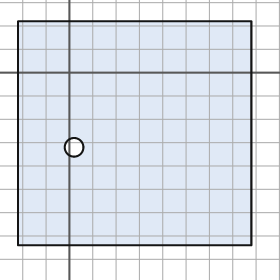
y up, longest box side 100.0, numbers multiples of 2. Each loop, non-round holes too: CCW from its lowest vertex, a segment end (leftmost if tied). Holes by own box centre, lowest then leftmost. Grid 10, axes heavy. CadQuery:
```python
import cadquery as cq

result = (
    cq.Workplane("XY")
    .moveTo(-22.0, -74.0)
    .lineTo(78.0, -74.0)
    .lineTo(78.0, 22.0)
    .lineTo(-22.0, 22.0)
    .close()
    .moveTo(2.0, -32.0)
    .circle(4.0)
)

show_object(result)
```